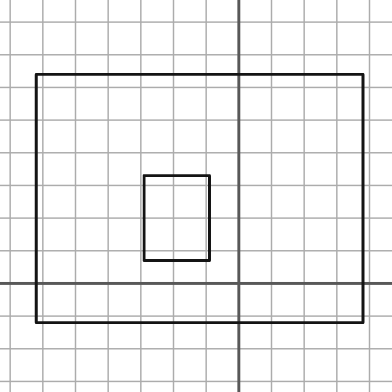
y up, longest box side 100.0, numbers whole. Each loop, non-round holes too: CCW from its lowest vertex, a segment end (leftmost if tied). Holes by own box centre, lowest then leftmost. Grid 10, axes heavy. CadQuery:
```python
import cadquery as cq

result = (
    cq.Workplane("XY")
    .moveTo(-62.0, -12.0)
    .lineTo(38.0, -12.0)
    .lineTo(38.0, 64.0)
    .lineTo(-62.0, 64.0)
    .close()
    .moveTo(-29.0, 7.0)
    .lineTo(-9.0, 7.0)
    .lineTo(-9.0, 33.0)
    .lineTo(-29.0, 33.0)
    .close()
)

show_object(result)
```